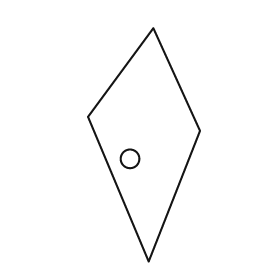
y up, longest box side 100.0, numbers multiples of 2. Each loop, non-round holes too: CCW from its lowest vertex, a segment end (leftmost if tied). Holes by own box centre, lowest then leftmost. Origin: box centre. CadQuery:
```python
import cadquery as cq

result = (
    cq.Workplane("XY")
    .moveTo(2.0, -50.0)
    .lineTo(24.0, 6.0)
    .lineTo(4.0, 50.0)
    .lineTo(-24.0, 12.0)
    .close()
    .moveTo(-6.0, -6.0)
    .circle(4.0)
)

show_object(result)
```